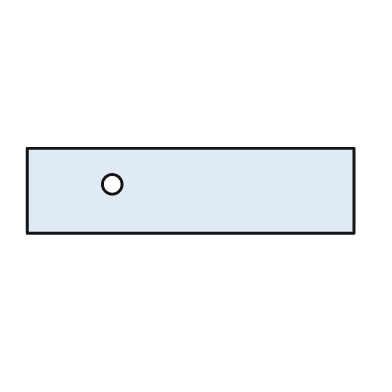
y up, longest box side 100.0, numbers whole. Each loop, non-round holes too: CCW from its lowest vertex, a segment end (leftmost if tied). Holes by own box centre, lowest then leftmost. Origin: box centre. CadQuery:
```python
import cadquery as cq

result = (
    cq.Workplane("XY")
    .moveTo(-50.0, -13.0)
    .lineTo(50.0, -13.0)
    .lineTo(50.0, 13.0)
    .lineTo(-50.0, 13.0)
    .close()
    .moveTo(-24.0, 2.0)
    .circle(3.0)
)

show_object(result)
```